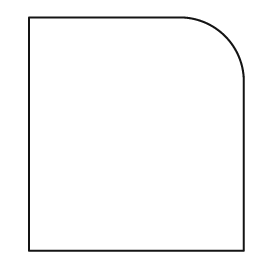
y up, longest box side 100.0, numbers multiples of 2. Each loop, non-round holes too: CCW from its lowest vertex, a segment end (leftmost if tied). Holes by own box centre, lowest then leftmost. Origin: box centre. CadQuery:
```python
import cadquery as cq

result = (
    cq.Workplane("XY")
    .moveTo(-46.0, -50.0)
    .lineTo(46.0, -50.0)
    .lineTo(46.0, 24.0)
    .threePointArc((38.0, 42.0), (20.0, 50.0))
    .lineTo(-46.0, 50.0)
    .close()
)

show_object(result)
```